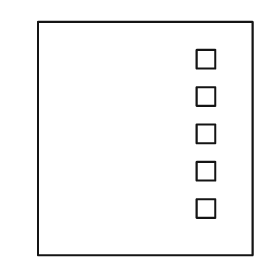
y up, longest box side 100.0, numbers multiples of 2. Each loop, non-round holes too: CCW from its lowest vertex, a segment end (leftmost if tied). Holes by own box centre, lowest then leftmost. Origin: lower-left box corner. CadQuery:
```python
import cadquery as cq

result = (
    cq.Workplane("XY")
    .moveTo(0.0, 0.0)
    .lineTo(92.0, 0.0)
    .lineTo(92.0, 100.0)
    .lineTo(0.0, 100.0)
    .close()
    .moveTo(68.0, 16.0)
    .lineTo(76.0, 16.0)
    .lineTo(76.0, 24.0)
    .lineTo(68.0, 24.0)
    .close()
    .moveTo(68.0, 32.0)
    .lineTo(76.0, 32.0)
    .lineTo(76.0, 40.0)
    .lineTo(68.0, 40.0)
    .close()
    .moveTo(68.0, 48.0)
    .lineTo(76.0, 48.0)
    .lineTo(76.0, 56.0)
    .lineTo(68.0, 56.0)
    .close()
    .moveTo(68.0, 64.0)
    .lineTo(76.0, 64.0)
    .lineTo(76.0, 72.0)
    .lineTo(68.0, 72.0)
    .close()
    .moveTo(68.0, 80.0)
    .lineTo(76.0, 80.0)
    .lineTo(76.0, 88.0)
    .lineTo(68.0, 88.0)
    .close()
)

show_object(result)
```